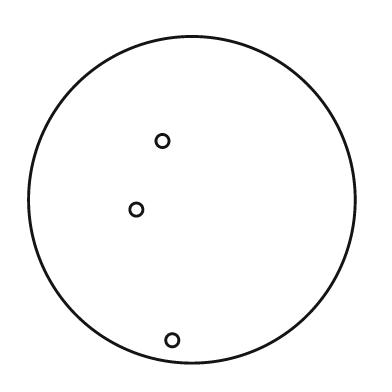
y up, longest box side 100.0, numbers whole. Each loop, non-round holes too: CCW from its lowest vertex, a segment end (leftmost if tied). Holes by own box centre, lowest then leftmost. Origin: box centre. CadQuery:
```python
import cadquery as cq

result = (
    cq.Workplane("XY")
    .moveTo(0.0, 0.0)
    .circle(50.0)
    .moveTo(-6.0, -43.0)
    .circle(2.0)
    .moveTo(-17.0, -3.0)
    .circle(2.0)
    .moveTo(-9.0, 18.0)
    .circle(2.0)
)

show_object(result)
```